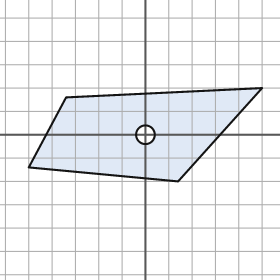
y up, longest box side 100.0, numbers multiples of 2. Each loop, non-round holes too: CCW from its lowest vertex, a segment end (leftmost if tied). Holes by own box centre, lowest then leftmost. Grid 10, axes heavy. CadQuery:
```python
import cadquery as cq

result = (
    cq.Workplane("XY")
    .moveTo(14.0, -20.0)
    .lineTo(50.0, 20.0)
    .lineTo(-34.0, 16.0)
    .lineTo(-50.0, -14.0)
    .close()
    .moveTo(0.0, 0.0)
    .circle(4.0)
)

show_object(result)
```